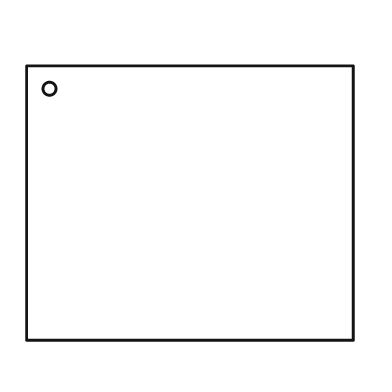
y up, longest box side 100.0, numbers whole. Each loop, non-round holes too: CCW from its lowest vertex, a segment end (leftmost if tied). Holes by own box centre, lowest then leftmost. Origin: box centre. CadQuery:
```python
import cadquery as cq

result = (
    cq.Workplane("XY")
    .moveTo(-50.0, -42.0)
    .lineTo(50.0, -42.0)
    .lineTo(50.0, 42.0)
    .lineTo(-50.0, 42.0)
    .close()
    .moveTo(-43.0, 35.0)
    .circle(2.0)
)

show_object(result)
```